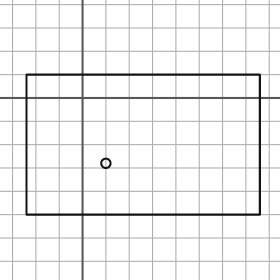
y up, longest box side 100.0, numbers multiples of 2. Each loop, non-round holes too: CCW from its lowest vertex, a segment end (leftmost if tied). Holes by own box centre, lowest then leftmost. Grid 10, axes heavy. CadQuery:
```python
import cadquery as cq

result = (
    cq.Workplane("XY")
    .moveTo(-24.0, -50.0)
    .lineTo(76.0, -50.0)
    .lineTo(76.0, 10.0)
    .lineTo(-24.0, 10.0)
    .close()
    .moveTo(10.0, -28.0)
    .circle(2.0)
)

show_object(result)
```